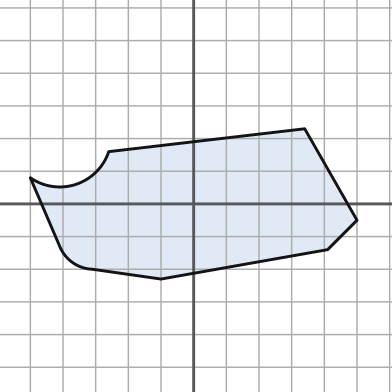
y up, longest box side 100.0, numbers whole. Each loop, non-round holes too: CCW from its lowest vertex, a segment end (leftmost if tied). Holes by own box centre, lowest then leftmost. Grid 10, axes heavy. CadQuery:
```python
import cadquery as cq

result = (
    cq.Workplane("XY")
    .moveTo(-10.0, -23.0)
    .lineTo(41.0, -14.0)
    .lineTo(50.0, -5.0)
    .lineTo(34.0, 23.0)
    .lineTo(-26.0, 16.0)
    .threePointArc((-36.0, 6.0), (-50.0, 8.0))
    .lineTo(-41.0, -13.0)
    .threePointArc((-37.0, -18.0), (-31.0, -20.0))
    .close()
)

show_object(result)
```